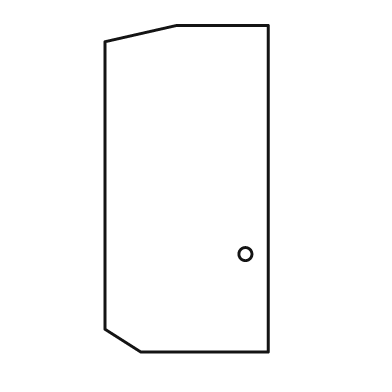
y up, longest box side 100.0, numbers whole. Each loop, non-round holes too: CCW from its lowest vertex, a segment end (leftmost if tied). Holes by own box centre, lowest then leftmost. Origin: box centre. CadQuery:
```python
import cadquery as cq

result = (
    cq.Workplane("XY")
    .moveTo(-14.0, -50.0)
    .lineTo(25.0, -50.0)
    .lineTo(25.0, 50.0)
    .lineTo(-3.0, 50.0)
    .lineTo(-25.0, 45.0)
    .lineTo(-25.0, -43.0)
    .close()
    .moveTo(18.0, -20.0)
    .circle(2.0)
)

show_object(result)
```